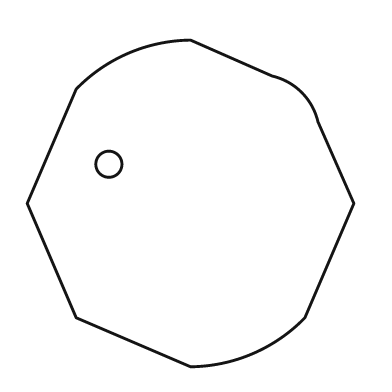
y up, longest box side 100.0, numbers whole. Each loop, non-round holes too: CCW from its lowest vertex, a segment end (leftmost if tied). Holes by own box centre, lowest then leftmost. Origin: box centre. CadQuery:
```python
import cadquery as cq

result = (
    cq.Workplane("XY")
    .moveTo(0.0, -50.0)
    .threePointArc((19.0, -46.0), (35.0, -35.0))
    .lineTo(50.0, 0.0)
    .lineTo(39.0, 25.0)
    .threePointArc((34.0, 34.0), (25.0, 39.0))
    .lineTo(0.0, 50.0)
    .threePointArc((-19.0, 46.0), (-35.0, 35.0))
    .lineTo(-50.0, 0.0)
    .lineTo(-35.0, -35.0)
    .close()
    .moveTo(-25.0, 12.0)
    .circle(4.0)
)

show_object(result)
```